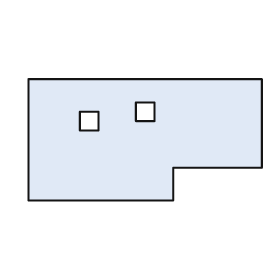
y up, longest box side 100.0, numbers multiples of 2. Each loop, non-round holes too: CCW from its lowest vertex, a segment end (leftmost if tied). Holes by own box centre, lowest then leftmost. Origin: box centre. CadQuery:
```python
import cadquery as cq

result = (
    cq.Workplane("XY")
    .moveTo(-50.0, -26.0)
    .lineTo(12.0, -26.0)
    .lineTo(12.0, -12.0)
    .lineTo(50.0, -12.0)
    .lineTo(50.0, 26.0)
    .lineTo(-50.0, 26.0)
    .close()
    .moveTo(-28.0, 4.0)
    .lineTo(-20.0, 4.0)
    .lineTo(-20.0, 12.0)
    .lineTo(-28.0, 12.0)
    .close()
    .moveTo(-4.0, 8.0)
    .lineTo(4.0, 8.0)
    .lineTo(4.0, 16.0)
    .lineTo(-4.0, 16.0)
    .close()
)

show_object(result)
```